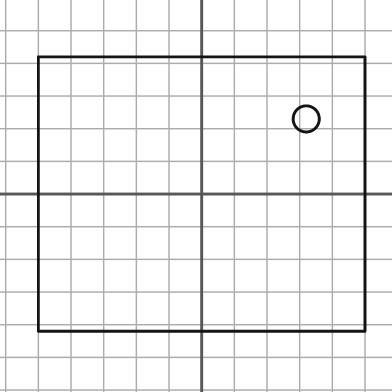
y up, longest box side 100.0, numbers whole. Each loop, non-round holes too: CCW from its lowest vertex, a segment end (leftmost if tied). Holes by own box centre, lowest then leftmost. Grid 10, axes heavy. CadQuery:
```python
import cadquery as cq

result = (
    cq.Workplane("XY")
    .moveTo(-50.0, -42.0)
    .lineTo(50.0, -42.0)
    .lineTo(50.0, 42.0)
    .lineTo(-50.0, 42.0)
    .close()
    .moveTo(32.0, 23.0)
    .circle(4.0)
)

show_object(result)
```